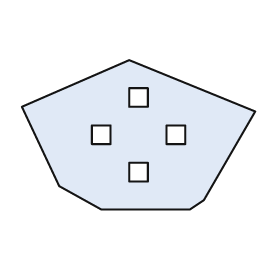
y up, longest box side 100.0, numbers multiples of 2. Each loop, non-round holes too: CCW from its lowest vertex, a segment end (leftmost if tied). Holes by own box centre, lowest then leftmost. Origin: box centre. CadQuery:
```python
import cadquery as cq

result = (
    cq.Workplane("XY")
    .moveTo(-16.0, -32.0)
    .lineTo(22.0, -32.0)
    .lineTo(28.0, -28.0)
    .lineTo(50.0, 10.0)
    .lineTo(-4.0, 32.0)
    .lineTo(-50.0, 12.0)
    .lineTo(-34.0, -22.0)
    .close()
    .moveTo(-4.0, -20.0)
    .lineTo(4.0, -20.0)
    .lineTo(4.0, -12.0)
    .lineTo(-4.0, -12.0)
    .close()
    .moveTo(-20.0, -4.0)
    .lineTo(-12.0, -4.0)
    .lineTo(-12.0, 4.0)
    .lineTo(-20.0, 4.0)
    .close()
    .moveTo(12.0, -4.0)
    .lineTo(20.0, -4.0)
    .lineTo(20.0, 4.0)
    .lineTo(12.0, 4.0)
    .close()
    .moveTo(-4.0, 12.0)
    .lineTo(4.0, 12.0)
    .lineTo(4.0, 20.0)
    .lineTo(-4.0, 20.0)
    .close()
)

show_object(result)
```